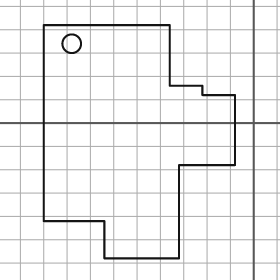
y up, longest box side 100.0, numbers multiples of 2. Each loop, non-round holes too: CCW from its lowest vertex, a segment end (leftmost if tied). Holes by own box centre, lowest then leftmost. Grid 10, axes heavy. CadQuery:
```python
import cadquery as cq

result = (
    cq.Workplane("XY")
    .moveTo(-64.0, -58.0)
    .lineTo(-32.0, -58.0)
    .lineTo(-32.0, -18.0)
    .lineTo(-8.0, -18.0)
    .lineTo(-8.0, 12.0)
    .lineTo(-22.0, 12.0)
    .lineTo(-22.0, 16.0)
    .lineTo(-36.0, 16.0)
    .lineTo(-36.0, 42.0)
    .lineTo(-90.0, 42.0)
    .lineTo(-90.0, -42.0)
    .lineTo(-64.0, -42.0)
    .close()
    .moveTo(-78.0, 34.0)
    .circle(4.0)
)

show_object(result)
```